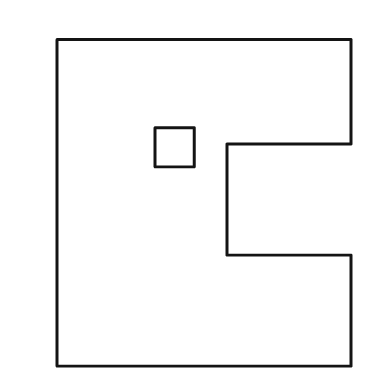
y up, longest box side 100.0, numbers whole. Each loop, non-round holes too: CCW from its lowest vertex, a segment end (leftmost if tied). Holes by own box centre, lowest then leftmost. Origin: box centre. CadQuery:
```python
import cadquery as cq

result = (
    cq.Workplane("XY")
    .moveTo(-45.0, -50.0)
    .lineTo(45.0, -50.0)
    .lineTo(45.0, -16.0)
    .lineTo(7.0, -16.0)
    .lineTo(7.0, 18.0)
    .lineTo(45.0, 18.0)
    .lineTo(45.0, 50.0)
    .lineTo(-45.0, 50.0)
    .close()
    .moveTo(-15.0, 11.0)
    .lineTo(-3.0, 11.0)
    .lineTo(-3.0, 23.0)
    .lineTo(-15.0, 23.0)
    .close()
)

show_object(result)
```